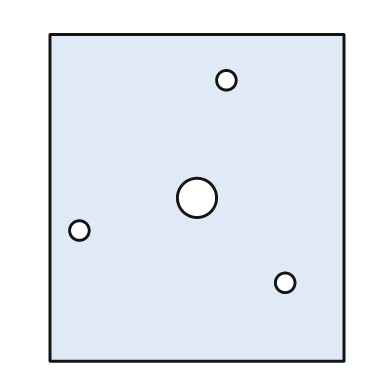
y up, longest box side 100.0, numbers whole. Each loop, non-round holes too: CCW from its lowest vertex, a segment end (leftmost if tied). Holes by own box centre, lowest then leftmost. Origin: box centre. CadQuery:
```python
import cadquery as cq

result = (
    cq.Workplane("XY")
    .moveTo(-45.0, -50.0)
    .lineTo(45.0, -50.0)
    .lineTo(45.0, 50.0)
    .lineTo(-45.0, 50.0)
    .close()
    .moveTo(27.0, -26.0)
    .circle(3.0)
    .moveTo(-36.0, -10.0)
    .circle(3.0)
    .moveTo(0.0, 0.0)
    .circle(6.0)
    .moveTo(9.0, 36.0)
    .circle(3.0)
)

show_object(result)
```